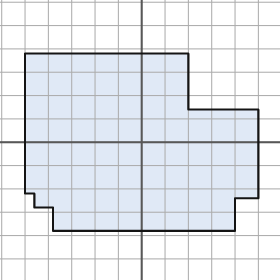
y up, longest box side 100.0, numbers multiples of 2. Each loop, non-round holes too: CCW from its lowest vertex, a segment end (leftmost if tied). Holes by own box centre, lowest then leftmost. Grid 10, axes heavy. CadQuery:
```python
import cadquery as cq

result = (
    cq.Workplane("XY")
    .moveTo(-38.0, -38.0)
    .lineTo(40.0, -38.0)
    .lineTo(40.0, -24.0)
    .lineTo(50.0, -24.0)
    .lineTo(50.0, 14.0)
    .lineTo(20.0, 14.0)
    .lineTo(20.0, 38.0)
    .lineTo(-50.0, 38.0)
    .lineTo(-50.0, -22.0)
    .lineTo(-46.0, -22.0)
    .lineTo(-46.0, -28.0)
    .lineTo(-38.0, -28.0)
    .close()
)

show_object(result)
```